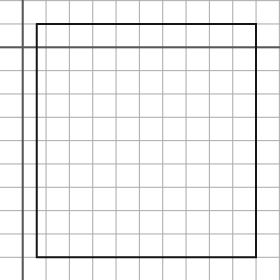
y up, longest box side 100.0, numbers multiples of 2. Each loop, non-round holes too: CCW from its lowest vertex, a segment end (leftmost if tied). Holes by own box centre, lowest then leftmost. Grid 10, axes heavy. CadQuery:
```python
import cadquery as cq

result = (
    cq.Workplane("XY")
    .moveTo(6.0, -90.0)
    .lineTo(100.0, -90.0)
    .lineTo(100.0, 10.0)
    .lineTo(6.0, 10.0)
    .close()
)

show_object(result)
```